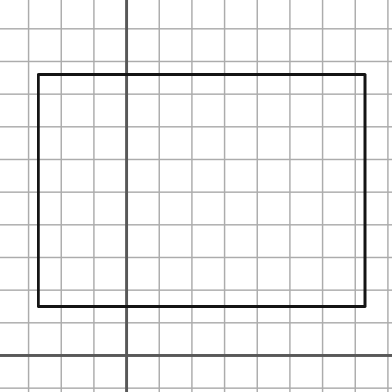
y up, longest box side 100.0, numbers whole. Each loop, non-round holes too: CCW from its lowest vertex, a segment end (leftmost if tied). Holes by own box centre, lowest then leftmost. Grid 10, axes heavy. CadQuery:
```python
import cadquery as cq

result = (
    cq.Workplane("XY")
    .moveTo(-27.0, 15.0)
    .lineTo(73.0, 15.0)
    .lineTo(73.0, 86.0)
    .lineTo(-27.0, 86.0)
    .close()
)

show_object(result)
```